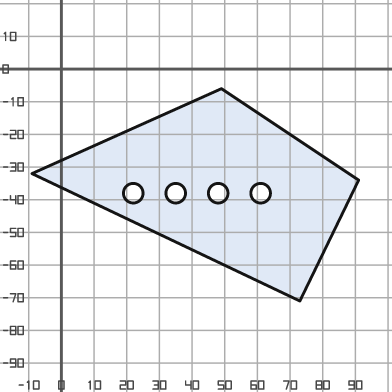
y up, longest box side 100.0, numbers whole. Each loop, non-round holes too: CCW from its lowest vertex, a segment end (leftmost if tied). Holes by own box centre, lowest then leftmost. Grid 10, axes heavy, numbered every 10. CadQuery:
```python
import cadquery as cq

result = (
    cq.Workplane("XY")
    .moveTo(73.0, -71.0)
    .lineTo(91.0, -34.0)
    .lineTo(49.0, -6.0)
    .lineTo(-9.0, -32.0)
    .close()
    .moveTo(22.0, -38.0)
    .circle(3.0)
    .moveTo(35.0, -38.0)
    .circle(3.0)
    .moveTo(48.0, -38.0)
    .circle(3.0)
    .moveTo(61.0, -38.0)
    .circle(3.0)
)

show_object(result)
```